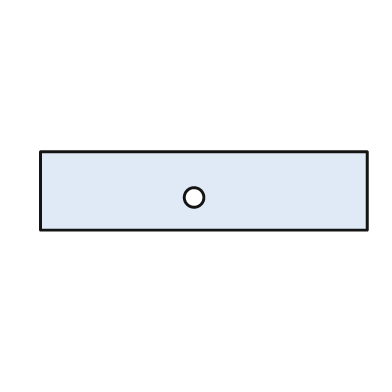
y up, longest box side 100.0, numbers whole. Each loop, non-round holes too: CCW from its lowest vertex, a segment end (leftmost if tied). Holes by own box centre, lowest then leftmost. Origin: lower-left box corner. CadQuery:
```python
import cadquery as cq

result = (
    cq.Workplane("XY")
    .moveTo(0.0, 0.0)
    .lineTo(100.0, 0.0)
    .lineTo(100.0, 24.0)
    .lineTo(0.0, 24.0)
    .close()
    .moveTo(47.0, 10.0)
    .circle(3.0)
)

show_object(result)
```